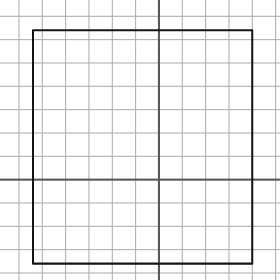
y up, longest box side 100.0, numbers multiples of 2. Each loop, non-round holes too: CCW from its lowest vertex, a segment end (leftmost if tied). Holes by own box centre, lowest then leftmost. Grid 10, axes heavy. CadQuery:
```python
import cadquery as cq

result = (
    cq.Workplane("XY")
    .moveTo(-54.0, -36.0)
    .lineTo(40.0, -36.0)
    .lineTo(40.0, 64.0)
    .lineTo(-54.0, 64.0)
    .close()
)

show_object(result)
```